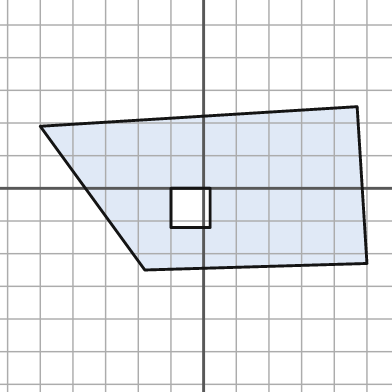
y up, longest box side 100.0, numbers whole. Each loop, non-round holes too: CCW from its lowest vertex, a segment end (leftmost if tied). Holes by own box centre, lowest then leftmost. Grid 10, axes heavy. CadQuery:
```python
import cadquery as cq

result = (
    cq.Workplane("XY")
    .moveTo(-18.0, -25.0)
    .lineTo(50.0, -23.0)
    .lineTo(47.0, 25.0)
    .lineTo(-50.0, 19.0)
    .close()
    .moveTo(-10.0, -12.0)
    .lineTo(2.0, -12.0)
    .lineTo(2.0, 0.0)
    .lineTo(-10.0, 0.0)
    .close()
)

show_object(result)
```